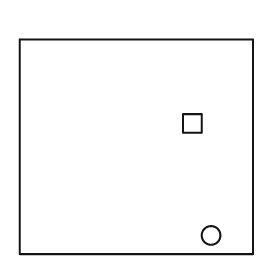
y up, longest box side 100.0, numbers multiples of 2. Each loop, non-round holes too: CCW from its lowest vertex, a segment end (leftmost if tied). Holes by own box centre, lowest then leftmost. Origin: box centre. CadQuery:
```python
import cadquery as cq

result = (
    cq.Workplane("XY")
    .moveTo(-50.0, -46.0)
    .lineTo(50.0, -46.0)
    .lineTo(50.0, 46.0)
    .lineTo(-50.0, 46.0)
    .close()
    .moveTo(32.0, -38.0)
    .circle(4.0)
    .moveTo(20.0, 6.0)
    .lineTo(28.0, 6.0)
    .lineTo(28.0, 14.0)
    .lineTo(20.0, 14.0)
    .close()
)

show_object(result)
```